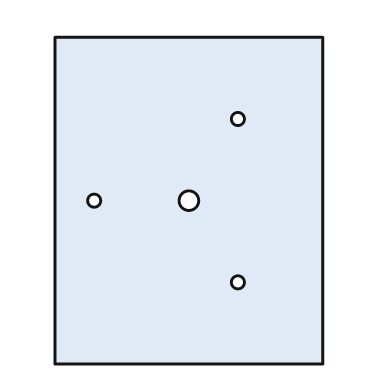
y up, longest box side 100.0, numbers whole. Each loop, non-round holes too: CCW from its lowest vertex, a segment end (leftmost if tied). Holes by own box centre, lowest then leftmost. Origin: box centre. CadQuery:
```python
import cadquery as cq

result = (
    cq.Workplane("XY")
    .moveTo(-41.0, -50.0)
    .lineTo(41.0, -50.0)
    .lineTo(41.0, 50.0)
    .lineTo(-41.0, 50.0)
    .close()
    .moveTo(15.0, -25.0)
    .circle(2.0)
    .moveTo(-29.0, 0.0)
    .circle(2.0)
    .moveTo(0.0, 0.0)
    .circle(3.0)
    .moveTo(15.0, 25.0)
    .circle(2.0)
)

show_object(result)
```